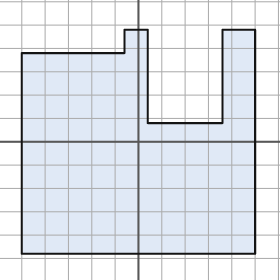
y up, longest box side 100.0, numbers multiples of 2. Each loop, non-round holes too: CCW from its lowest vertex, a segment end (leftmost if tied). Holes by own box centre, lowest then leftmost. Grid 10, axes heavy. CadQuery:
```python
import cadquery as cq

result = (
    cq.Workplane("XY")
    .moveTo(-50.0, -48.0)
    .lineTo(50.0, -48.0)
    .lineTo(50.0, 48.0)
    .lineTo(36.0, 48.0)
    .lineTo(36.0, 8.0)
    .lineTo(4.0, 8.0)
    .lineTo(4.0, 48.0)
    .lineTo(-6.0, 48.0)
    .lineTo(-6.0, 38.0)
    .lineTo(-50.0, 38.0)
    .close()
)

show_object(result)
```